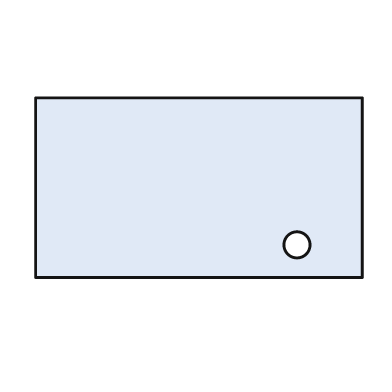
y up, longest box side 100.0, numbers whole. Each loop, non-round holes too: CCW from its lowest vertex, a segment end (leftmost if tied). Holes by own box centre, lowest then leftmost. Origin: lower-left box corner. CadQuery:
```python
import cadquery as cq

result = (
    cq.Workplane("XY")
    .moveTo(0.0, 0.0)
    .lineTo(100.0, 0.0)
    .lineTo(100.0, 55.0)
    .lineTo(0.0, 55.0)
    .close()
    .moveTo(80.0, 10.0)
    .circle(4.0)
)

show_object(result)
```